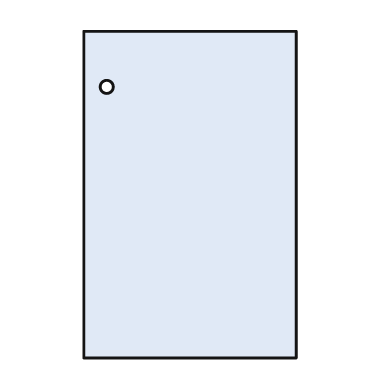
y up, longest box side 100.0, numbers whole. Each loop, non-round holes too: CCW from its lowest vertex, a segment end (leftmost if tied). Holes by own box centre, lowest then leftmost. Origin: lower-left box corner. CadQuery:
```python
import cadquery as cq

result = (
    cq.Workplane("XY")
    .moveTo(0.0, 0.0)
    .lineTo(65.0, 0.0)
    .lineTo(65.0, 100.0)
    .lineTo(0.0, 100.0)
    .close()
    .moveTo(7.0, 83.0)
    .circle(2.0)
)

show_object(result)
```